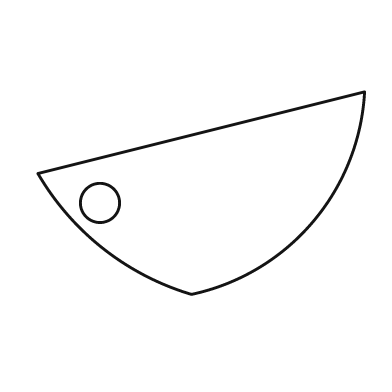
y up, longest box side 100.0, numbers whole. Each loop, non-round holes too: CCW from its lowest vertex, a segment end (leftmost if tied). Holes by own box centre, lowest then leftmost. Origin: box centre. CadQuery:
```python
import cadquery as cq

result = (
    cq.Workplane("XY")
    .moveTo(-3.0, -31.0)
    .threePointArc((34.0, -9.0), (50.0, 31.0))
    .lineTo(-50.0, 6.0)
    .threePointArc((-30.0, -17.0), (-3.0, -31.0))
    .close()
    .moveTo(-31.0, -3.0)
    .circle(6.0)
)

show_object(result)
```